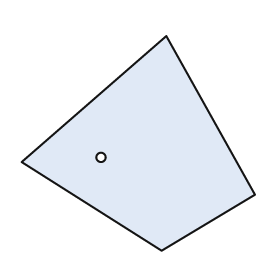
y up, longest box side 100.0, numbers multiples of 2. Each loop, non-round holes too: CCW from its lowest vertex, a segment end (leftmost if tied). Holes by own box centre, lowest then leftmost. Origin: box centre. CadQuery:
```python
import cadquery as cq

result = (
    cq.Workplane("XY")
    .moveTo(10.0, -46.0)
    .lineTo(50.0, -22.0)
    .lineTo(12.0, 46.0)
    .lineTo(-50.0, -8.0)
    .close()
    .moveTo(-16.0, -6.0)
    .circle(2.0)
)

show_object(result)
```